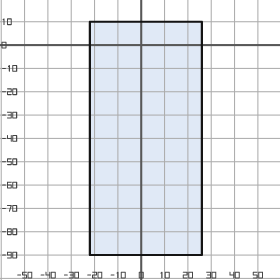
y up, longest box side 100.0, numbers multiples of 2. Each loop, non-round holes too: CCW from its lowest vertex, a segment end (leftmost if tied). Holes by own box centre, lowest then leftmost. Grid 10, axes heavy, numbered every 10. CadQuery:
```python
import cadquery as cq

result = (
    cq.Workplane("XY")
    .moveTo(-22.0, -90.0)
    .lineTo(26.0, -90.0)
    .lineTo(26.0, 10.0)
    .lineTo(-22.0, 10.0)
    .close()
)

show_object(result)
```